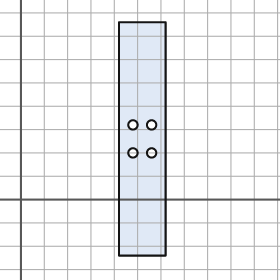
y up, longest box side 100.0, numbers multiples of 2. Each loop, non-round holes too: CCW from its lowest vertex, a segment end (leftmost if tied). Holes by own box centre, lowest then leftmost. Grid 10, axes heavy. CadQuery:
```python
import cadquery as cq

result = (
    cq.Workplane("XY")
    .moveTo(42.0, -24.0)
    .lineTo(62.0, -24.0)
    .lineTo(62.0, 76.0)
    .lineTo(42.0, 76.0)
    .close()
    .moveTo(48.0, 20.0)
    .circle(2.0)
    .moveTo(56.0, 20.0)
    .circle(2.0)
    .moveTo(48.0, 32.0)
    .circle(2.0)
    .moveTo(56.0, 32.0)
    .circle(2.0)
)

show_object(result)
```